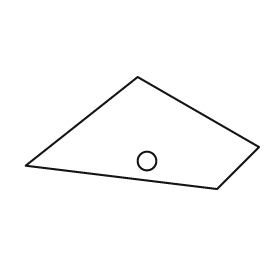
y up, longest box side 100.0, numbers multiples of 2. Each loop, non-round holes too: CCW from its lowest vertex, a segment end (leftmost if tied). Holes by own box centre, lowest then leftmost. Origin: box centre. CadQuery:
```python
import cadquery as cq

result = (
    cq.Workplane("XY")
    .moveTo(32.0, -24.0)
    .lineTo(50.0, -6.0)
    .lineTo(-2.0, 24.0)
    .lineTo(-50.0, -14.0)
    .close()
    .moveTo(2.0, -12.0)
    .circle(4.0)
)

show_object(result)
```